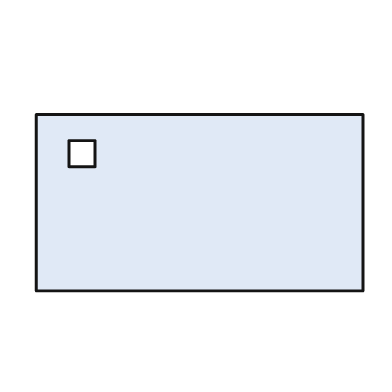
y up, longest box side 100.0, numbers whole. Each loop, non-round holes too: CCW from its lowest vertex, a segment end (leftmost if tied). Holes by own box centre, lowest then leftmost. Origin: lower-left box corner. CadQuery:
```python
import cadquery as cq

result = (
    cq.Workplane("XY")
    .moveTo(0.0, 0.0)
    .lineTo(100.0, 0.0)
    .lineTo(100.0, 54.0)
    .lineTo(0.0, 54.0)
    .close()
    .moveTo(10.0, 38.0)
    .lineTo(18.0, 38.0)
    .lineTo(18.0, 46.0)
    .lineTo(10.0, 46.0)
    .close()
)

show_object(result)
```